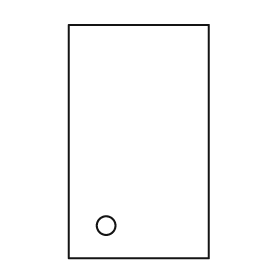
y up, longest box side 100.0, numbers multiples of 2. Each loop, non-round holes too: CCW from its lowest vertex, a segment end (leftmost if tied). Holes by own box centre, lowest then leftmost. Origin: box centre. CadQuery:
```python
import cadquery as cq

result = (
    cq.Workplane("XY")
    .moveTo(-30.0, -50.0)
    .lineTo(30.0, -50.0)
    .lineTo(30.0, 50.0)
    .lineTo(-30.0, 50.0)
    .close()
    .moveTo(-14.0, -36.0)
    .circle(4.0)
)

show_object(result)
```